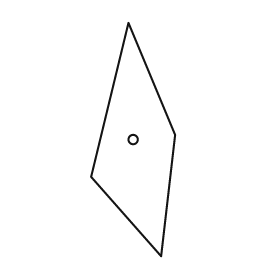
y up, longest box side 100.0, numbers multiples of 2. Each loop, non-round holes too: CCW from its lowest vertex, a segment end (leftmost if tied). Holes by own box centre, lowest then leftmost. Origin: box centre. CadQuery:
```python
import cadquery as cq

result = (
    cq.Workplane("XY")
    .moveTo(12.0, -50.0)
    .lineTo(18.0, 2.0)
    .lineTo(-2.0, 50.0)
    .lineTo(-18.0, -16.0)
    .close()
    .moveTo(0.0, 0.0)
    .circle(2.0)
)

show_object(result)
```